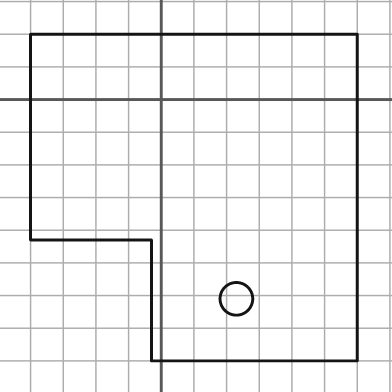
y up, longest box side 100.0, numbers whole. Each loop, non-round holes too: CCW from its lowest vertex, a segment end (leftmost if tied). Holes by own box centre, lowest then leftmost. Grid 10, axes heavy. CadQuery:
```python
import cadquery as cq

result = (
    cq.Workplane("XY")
    .moveTo(-3.0, -80.0)
    .lineTo(60.0, -80.0)
    .lineTo(60.0, 20.0)
    .lineTo(-40.0, 20.0)
    .lineTo(-40.0, -43.0)
    .lineTo(-3.0, -43.0)
    .close()
    .moveTo(23.0, -61.0)
    .circle(5.0)
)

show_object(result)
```